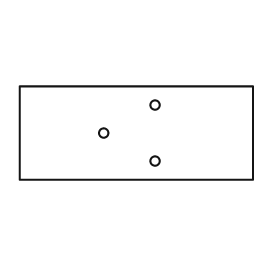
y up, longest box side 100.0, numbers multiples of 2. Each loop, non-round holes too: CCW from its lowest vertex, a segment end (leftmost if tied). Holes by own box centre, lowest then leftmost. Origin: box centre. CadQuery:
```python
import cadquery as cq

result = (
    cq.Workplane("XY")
    .moveTo(-50.0, -20.0)
    .lineTo(50.0, -20.0)
    .lineTo(50.0, 20.0)
    .lineTo(-50.0, 20.0)
    .close()
    .moveTo(8.0, -12.0)
    .circle(2.0)
    .moveTo(-14.0, 0.0)
    .circle(2.0)
    .moveTo(8.0, 12.0)
    .circle(2.0)
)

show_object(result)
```